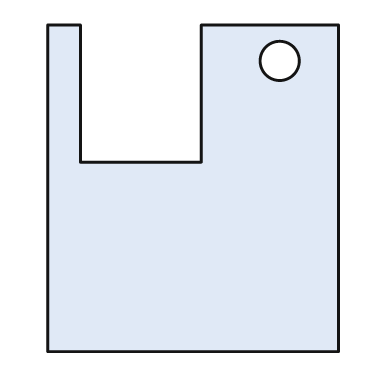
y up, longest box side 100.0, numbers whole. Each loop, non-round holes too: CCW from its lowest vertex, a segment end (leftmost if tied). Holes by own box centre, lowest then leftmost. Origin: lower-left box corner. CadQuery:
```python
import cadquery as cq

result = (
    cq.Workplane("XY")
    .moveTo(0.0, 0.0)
    .lineTo(89.0, 0.0)
    .lineTo(89.0, 100.0)
    .lineTo(47.0, 100.0)
    .lineTo(47.0, 58.0)
    .lineTo(10.0, 58.0)
    .lineTo(10.0, 100.0)
    .lineTo(0.0, 100.0)
    .close()
    .moveTo(71.0, 89.0)
    .circle(6.0)
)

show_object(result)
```